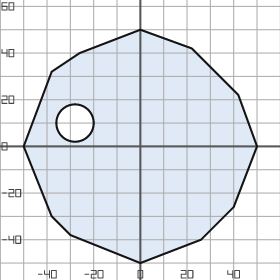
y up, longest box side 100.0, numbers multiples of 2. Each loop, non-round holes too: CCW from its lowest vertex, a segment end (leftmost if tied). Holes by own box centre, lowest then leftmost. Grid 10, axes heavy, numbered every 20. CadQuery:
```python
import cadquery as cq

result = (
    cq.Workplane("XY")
    .moveTo(0.0, -50.0)
    .lineTo(26.0, -40.0)
    .lineTo(40.0, -26.0)
    .lineTo(50.0, 0.0)
    .lineTo(42.0, 22.0)
    .lineTo(22.0, 42.0)
    .lineTo(0.0, 50.0)
    .lineTo(-26.0, 40.0)
    .lineTo(-38.0, 32.0)
    .lineTo(-50.0, 0.0)
    .lineTo(-38.0, -30.0)
    .lineTo(-30.0, -38.0)
    .close()
    .moveTo(-28.0, 10.0)
    .circle(8.0)
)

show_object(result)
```